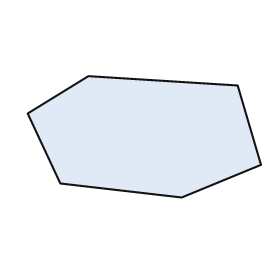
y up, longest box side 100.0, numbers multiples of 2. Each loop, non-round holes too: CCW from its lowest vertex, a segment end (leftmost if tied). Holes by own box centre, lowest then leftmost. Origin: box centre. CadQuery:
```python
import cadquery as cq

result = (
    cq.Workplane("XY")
    .moveTo(16.0, -26.0)
    .lineTo(50.0, -12.0)
    .lineTo(40.0, 22.0)
    .lineTo(-24.0, 26.0)
    .lineTo(-50.0, 10.0)
    .lineTo(-36.0, -20.0)
    .close()
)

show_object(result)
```